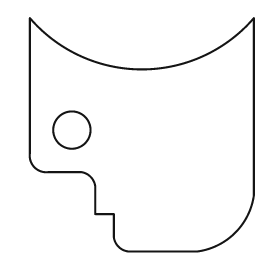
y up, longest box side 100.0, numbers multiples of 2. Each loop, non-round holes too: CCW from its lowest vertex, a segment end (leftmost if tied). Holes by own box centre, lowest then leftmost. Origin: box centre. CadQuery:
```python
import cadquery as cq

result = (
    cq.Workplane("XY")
    .moveTo(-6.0, -50.0)
    .lineTo(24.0, -50.0)
    .threePointArc((40.0, -42.0), (48.0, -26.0))
    .lineTo(48.0, 50.0)
    .threePointArc((0.0, 28.0), (-48.0, 50.0))
    .lineTo(-48.0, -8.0)
    .threePointArc((-46.0, -14.0), (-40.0, -16.0))
    .lineTo(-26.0, -16.0)
    .threePointArc((-22.0, -18.0), (-20.0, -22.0))
    .lineTo(-20.0, -34.0)
    .lineTo(-12.0, -34.0)
    .lineTo(-12.0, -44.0)
    .threePointArc((-10.0, -48.0), (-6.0, -50.0))
    .close()
    .moveTo(-30.0, 2.0)
    .circle(8.0)
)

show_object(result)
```